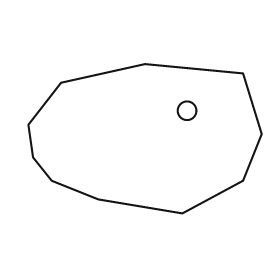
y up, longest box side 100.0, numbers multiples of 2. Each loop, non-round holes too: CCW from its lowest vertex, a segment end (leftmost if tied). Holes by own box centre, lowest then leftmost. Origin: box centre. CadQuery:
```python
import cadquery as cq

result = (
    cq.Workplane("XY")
    .moveTo(16.0, -32.0)
    .lineTo(42.0, -18.0)
    .lineTo(50.0, 2.0)
    .lineTo(42.0, 28.0)
    .lineTo(0.0, 32.0)
    .lineTo(-36.0, 24.0)
    .lineTo(-50.0, 6.0)
    .lineTo(-48.0, -8.0)
    .lineTo(-40.0, -18.0)
    .lineTo(-20.0, -26.0)
    .close()
    .moveTo(18.0, 12.0)
    .circle(4.0)
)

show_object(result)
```